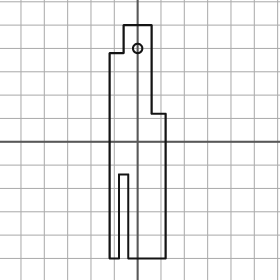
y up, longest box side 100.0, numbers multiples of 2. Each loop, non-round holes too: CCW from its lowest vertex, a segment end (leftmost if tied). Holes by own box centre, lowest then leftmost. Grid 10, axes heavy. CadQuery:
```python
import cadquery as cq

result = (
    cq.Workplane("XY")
    .moveTo(-12.0, -50.0)
    .lineTo(-8.0, -50.0)
    .lineTo(-8.0, -14.0)
    .lineTo(-4.0, -14.0)
    .lineTo(-4.0, -50.0)
    .lineTo(12.0, -50.0)
    .lineTo(12.0, 12.0)
    .lineTo(6.0, 12.0)
    .lineTo(6.0, 50.0)
    .lineTo(-6.0, 50.0)
    .lineTo(-6.0, 38.0)
    .lineTo(-12.0, 38.0)
    .close()
    .moveTo(0.0, 40.0)
    .circle(2.0)
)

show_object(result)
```